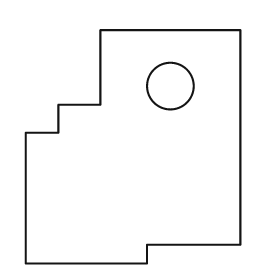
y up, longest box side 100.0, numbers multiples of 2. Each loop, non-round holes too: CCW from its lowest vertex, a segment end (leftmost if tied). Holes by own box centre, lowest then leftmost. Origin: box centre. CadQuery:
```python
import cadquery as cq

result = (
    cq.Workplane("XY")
    .moveTo(-46.0, -50.0)
    .lineTo(6.0, -50.0)
    .lineTo(6.0, -42.0)
    .lineTo(46.0, -42.0)
    .lineTo(46.0, 50.0)
    .lineTo(-14.0, 50.0)
    .lineTo(-14.0, 18.0)
    .lineTo(-32.0, 18.0)
    .lineTo(-32.0, 6.0)
    .lineTo(-46.0, 6.0)
    .close()
    .moveTo(16.0, 26.0)
    .circle(10.0)
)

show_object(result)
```